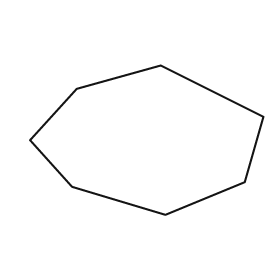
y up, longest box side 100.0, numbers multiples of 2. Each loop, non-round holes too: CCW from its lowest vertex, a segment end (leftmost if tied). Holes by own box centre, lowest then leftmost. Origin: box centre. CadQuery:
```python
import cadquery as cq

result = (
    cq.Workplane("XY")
    .moveTo(8.0, -32.0)
    .lineTo(42.0, -18.0)
    .lineTo(50.0, 10.0)
    .lineTo(6.0, 32.0)
    .lineTo(-30.0, 22.0)
    .lineTo(-50.0, 0.0)
    .lineTo(-32.0, -20.0)
    .close()
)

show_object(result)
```